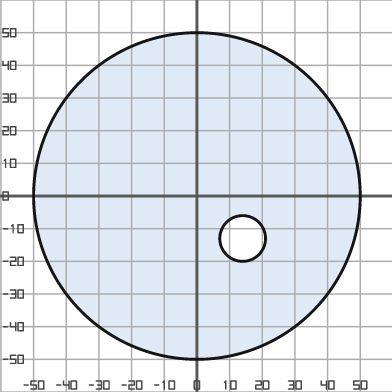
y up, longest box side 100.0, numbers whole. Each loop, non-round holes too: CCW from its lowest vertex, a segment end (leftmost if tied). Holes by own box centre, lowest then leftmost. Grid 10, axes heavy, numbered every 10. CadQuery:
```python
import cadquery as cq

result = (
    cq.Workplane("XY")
    .moveTo(0.0, 0.0)
    .circle(50.0)
    .moveTo(14.0, -13.0)
    .circle(7.0)
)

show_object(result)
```